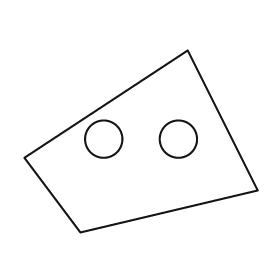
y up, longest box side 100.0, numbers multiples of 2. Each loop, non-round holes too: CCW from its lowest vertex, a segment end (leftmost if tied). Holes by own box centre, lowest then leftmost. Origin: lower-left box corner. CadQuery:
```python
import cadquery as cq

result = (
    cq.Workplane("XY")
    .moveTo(24.0, 0.0)
    .lineTo(100.0, 18.0)
    .lineTo(70.0, 78.0)
    .lineTo(0.0, 32.0)
    .close()
    .moveTo(34.0, 40.0)
    .circle(8.0)
    .moveTo(66.0, 40.0)
    .circle(8.0)
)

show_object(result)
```